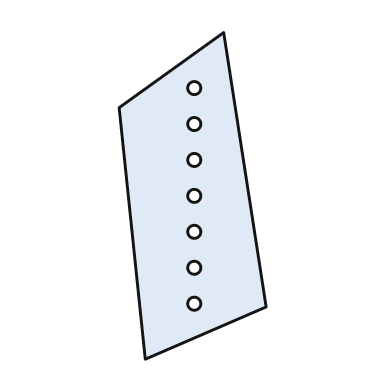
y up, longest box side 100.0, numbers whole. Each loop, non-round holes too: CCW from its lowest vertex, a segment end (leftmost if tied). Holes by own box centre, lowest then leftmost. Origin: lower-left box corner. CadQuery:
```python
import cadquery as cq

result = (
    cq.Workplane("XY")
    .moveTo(8.0, 0.0)
    .lineTo(45.0, 16.0)
    .lineTo(32.0, 100.0)
    .lineTo(0.0, 77.0)
    .close()
    .moveTo(23.0, 17.0)
    .circle(2.0)
    .moveTo(23.0, 28.0)
    .circle(2.0)
    .moveTo(23.0, 39.0)
    .circle(2.0)
    .moveTo(23.0, 50.0)
    .circle(2.0)
    .moveTo(23.0, 61.0)
    .circle(2.0)
    .moveTo(23.0, 72.0)
    .circle(2.0)
    .moveTo(23.0, 83.0)
    .circle(2.0)
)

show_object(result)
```